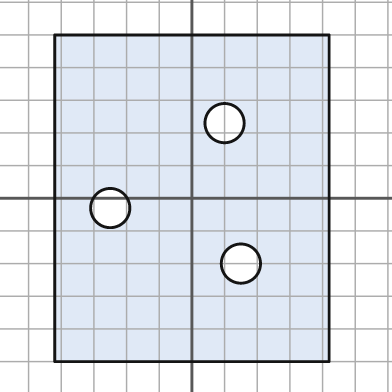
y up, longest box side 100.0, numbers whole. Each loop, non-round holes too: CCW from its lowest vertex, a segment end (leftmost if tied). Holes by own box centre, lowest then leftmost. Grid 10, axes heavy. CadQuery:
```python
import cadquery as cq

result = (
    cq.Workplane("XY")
    .moveTo(-42.0, -50.0)
    .lineTo(42.0, -50.0)
    .lineTo(42.0, 50.0)
    .lineTo(-42.0, 50.0)
    .close()
    .moveTo(15.0, -20.0)
    .circle(6.0)
    .moveTo(-25.0, -3.0)
    .circle(6.0)
    .moveTo(10.0, 23.0)
    .circle(6.0)
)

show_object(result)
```